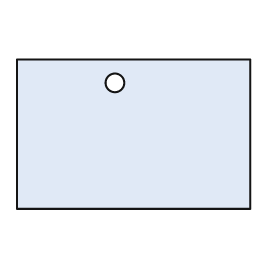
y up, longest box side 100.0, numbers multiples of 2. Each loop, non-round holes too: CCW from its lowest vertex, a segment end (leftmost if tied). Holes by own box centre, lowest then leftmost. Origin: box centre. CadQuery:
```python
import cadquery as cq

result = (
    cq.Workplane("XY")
    .moveTo(-50.0, -32.0)
    .lineTo(50.0, -32.0)
    .lineTo(50.0, 32.0)
    .lineTo(-50.0, 32.0)
    .close()
    .moveTo(-8.0, 22.0)
    .circle(4.0)
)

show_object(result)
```